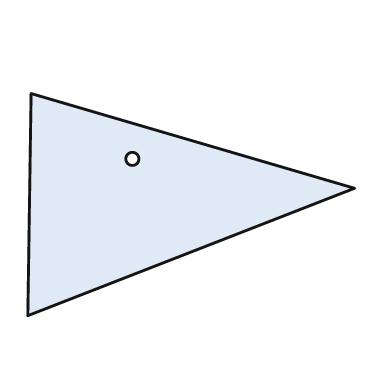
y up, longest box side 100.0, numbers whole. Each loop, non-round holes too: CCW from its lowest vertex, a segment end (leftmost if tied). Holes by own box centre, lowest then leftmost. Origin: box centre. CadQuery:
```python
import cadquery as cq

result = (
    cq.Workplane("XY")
    .moveTo(-50.0, -34.0)
    .lineTo(50.0, 5.0)
    .lineTo(-49.0, 34.0)
    .close()
    .moveTo(-18.0, 14.0)
    .circle(2.0)
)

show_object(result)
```